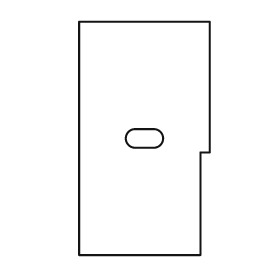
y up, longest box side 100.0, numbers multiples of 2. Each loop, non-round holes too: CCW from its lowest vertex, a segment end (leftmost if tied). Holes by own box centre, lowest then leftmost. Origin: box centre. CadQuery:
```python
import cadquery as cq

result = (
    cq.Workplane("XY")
    .moveTo(-28.0, -50.0)
    .lineTo(24.0, -50.0)
    .lineTo(24.0, -6.0)
    .lineTo(28.0, -6.0)
    .lineTo(28.0, 50.0)
    .lineTo(-28.0, 50.0)
    .close()
    .moveTo(-4.0, -4.0)
    .lineTo(4.0, -4.0)
    .threePointArc((8.0, 0.0), (4.0, 4.0))
    .lineTo(-4.0, 4.0)
    .threePointArc((-8.0, 0.0), (-4.0, -4.0))
    .close()
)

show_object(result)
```